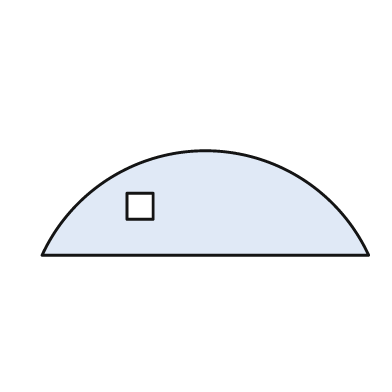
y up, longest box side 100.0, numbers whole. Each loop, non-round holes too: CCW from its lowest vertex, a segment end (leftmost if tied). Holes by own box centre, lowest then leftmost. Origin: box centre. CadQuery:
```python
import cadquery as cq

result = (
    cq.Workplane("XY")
    .moveTo(-50.0, -16.0)
    .lineTo(50.0, -16.0)
    .threePointArc((0.0, 16.0), (-50.0, -16.0))
    .close()
    .moveTo(-24.0, -5.0)
    .lineTo(-16.0, -5.0)
    .lineTo(-16.0, 3.0)
    .lineTo(-24.0, 3.0)
    .close()
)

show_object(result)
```